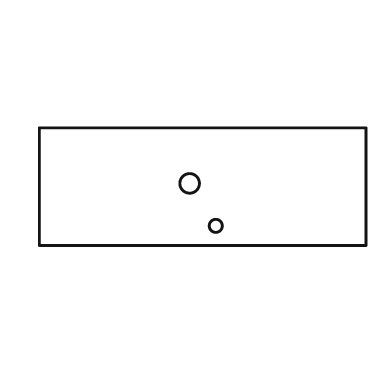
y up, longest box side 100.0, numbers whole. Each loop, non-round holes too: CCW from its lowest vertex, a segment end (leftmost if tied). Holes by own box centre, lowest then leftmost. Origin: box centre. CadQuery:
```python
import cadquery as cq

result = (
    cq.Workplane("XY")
    .moveTo(-50.0, -18.0)
    .lineTo(50.0, -18.0)
    .lineTo(50.0, 18.0)
    .lineTo(-50.0, 18.0)
    .close()
    .moveTo(4.0, -12.0)
    .circle(2.0)
    .moveTo(-4.0, 1.0)
    .circle(3.0)
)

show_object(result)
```